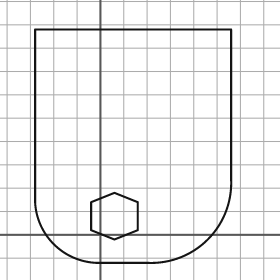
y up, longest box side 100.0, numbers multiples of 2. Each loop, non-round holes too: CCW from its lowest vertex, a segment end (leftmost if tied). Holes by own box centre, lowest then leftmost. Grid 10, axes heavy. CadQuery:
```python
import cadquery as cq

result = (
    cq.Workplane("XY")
    .moveTo(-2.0, -12.0)
    .lineTo(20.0, -12.0)
    .threePointArc((46.0, -2.0), (56.0, 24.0))
    .lineTo(56.0, 88.0)
    .lineTo(-28.0, 88.0)
    .lineTo(-28.0, 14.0)
    .threePointArc((-20.0, -4.0), (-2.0, -12.0))
    .close()
    .moveTo(6.0, -2.0)
    .lineTo(16.0, 2.0)
    .lineTo(16.0, 14.0)
    .lineTo(6.0, 18.0)
    .lineTo(-4.0, 14.0)
    .lineTo(-4.0, 2.0)
    .close()
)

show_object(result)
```